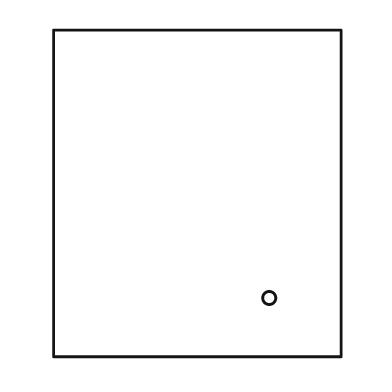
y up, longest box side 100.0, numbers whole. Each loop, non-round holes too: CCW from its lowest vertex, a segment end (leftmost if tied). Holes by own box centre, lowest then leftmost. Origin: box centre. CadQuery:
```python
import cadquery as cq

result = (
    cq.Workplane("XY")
    .moveTo(-44.0, -50.0)
    .lineTo(44.0, -50.0)
    .lineTo(44.0, 50.0)
    .lineTo(-44.0, 50.0)
    .close()
    .moveTo(22.0, -32.0)
    .circle(2.0)
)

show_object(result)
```